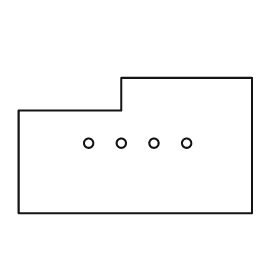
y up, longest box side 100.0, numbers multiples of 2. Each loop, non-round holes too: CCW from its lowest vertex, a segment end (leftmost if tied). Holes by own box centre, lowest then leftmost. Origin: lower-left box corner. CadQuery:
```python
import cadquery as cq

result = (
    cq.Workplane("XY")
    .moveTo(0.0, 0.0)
    .lineTo(100.0, 0.0)
    .lineTo(100.0, 58.0)
    .lineTo(44.0, 58.0)
    .lineTo(44.0, 44.0)
    .lineTo(0.0, 44.0)
    .close()
    .moveTo(30.0, 30.0)
    .circle(2.0)
    .moveTo(44.0, 30.0)
    .circle(2.0)
    .moveTo(58.0, 30.0)
    .circle(2.0)
    .moveTo(72.0, 30.0)
    .circle(2.0)
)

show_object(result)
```